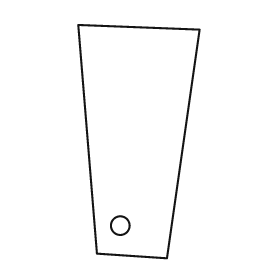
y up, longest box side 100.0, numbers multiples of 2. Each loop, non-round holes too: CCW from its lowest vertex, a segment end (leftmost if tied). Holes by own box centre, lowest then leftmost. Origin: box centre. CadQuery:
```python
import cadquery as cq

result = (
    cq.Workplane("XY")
    .moveTo(12.0, -50.0)
    .lineTo(26.0, 48.0)
    .lineTo(-26.0, 50.0)
    .lineTo(-18.0, -48.0)
    .close()
    .moveTo(-8.0, -36.0)
    .circle(4.0)
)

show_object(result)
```